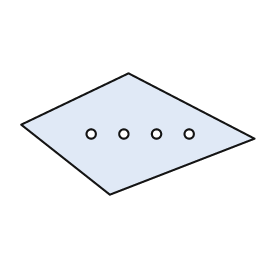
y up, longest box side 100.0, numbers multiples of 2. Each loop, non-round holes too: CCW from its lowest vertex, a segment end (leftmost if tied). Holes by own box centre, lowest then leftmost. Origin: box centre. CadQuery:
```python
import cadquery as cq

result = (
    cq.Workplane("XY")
    .moveTo(-12.0, -26.0)
    .lineTo(50.0, -2.0)
    .lineTo(-4.0, 26.0)
    .lineTo(-50.0, 4.0)
    .close()
    .moveTo(-20.0, 0.0)
    .circle(2.0)
    .moveTo(-6.0, 0.0)
    .circle(2.0)
    .moveTo(8.0, 0.0)
    .circle(2.0)
    .moveTo(22.0, 0.0)
    .circle(2.0)
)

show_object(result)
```